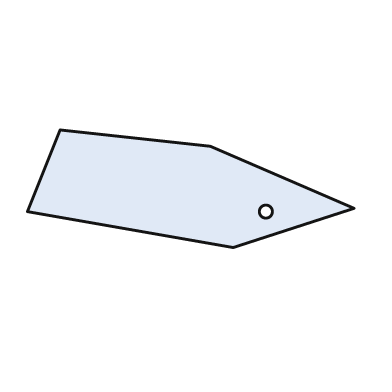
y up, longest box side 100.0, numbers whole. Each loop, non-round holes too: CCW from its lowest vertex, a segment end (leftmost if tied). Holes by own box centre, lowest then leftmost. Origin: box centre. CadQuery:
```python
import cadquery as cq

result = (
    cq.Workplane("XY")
    .moveTo(13.0, -18.0)
    .lineTo(50.0, -6.0)
    .lineTo(6.0, 13.0)
    .lineTo(-40.0, 18.0)
    .lineTo(-50.0, -7.0)
    .close()
    .moveTo(23.0, -7.0)
    .circle(2.0)
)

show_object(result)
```